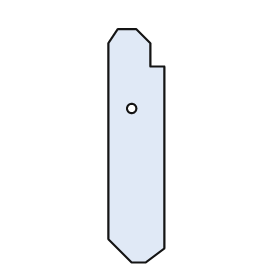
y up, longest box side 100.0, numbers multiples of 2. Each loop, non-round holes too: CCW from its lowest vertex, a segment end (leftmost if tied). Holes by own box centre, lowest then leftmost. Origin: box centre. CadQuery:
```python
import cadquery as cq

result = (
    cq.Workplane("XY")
    .moveTo(-2.0, -50.0)
    .lineTo(4.0, -50.0)
    .lineTo(12.0, -44.0)
    .lineTo(12.0, 34.0)
    .lineTo(6.0, 34.0)
    .lineTo(6.0, 44.0)
    .lineTo(0.0, 50.0)
    .lineTo(-8.0, 50.0)
    .lineTo(-12.0, 44.0)
    .lineTo(-12.0, -40.0)
    .close()
    .moveTo(-2.0, 16.0)
    .circle(2.0)
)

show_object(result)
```